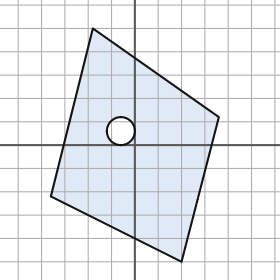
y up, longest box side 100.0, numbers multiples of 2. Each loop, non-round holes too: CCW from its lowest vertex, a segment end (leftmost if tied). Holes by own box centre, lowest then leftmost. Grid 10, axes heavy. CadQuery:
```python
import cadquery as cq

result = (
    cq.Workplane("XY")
    .moveTo(20.0, -50.0)
    .lineTo(36.0, 12.0)
    .lineTo(-18.0, 50.0)
    .lineTo(-36.0, -22.0)
    .close()
    .moveTo(-6.0, 6.0)
    .circle(6.0)
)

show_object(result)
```